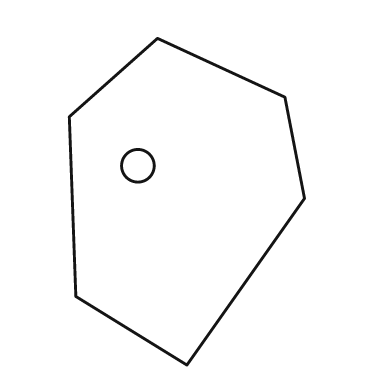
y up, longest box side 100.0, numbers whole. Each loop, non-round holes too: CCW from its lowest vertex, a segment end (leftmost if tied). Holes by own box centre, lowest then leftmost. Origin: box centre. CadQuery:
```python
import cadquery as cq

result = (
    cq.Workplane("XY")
    .moveTo(0.0, -50.0)
    .lineTo(36.0, 1.0)
    .lineTo(30.0, 32.0)
    .lineTo(-9.0, 50.0)
    .lineTo(-36.0, 26.0)
    .lineTo(-34.0, -29.0)
    .close()
    .moveTo(-15.0, 11.0)
    .circle(5.0)
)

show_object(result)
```